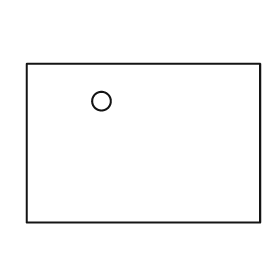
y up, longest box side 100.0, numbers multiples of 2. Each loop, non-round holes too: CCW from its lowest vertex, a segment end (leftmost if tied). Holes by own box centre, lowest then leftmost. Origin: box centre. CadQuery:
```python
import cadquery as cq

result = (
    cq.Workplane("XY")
    .moveTo(-50.0, -34.0)
    .lineTo(50.0, -34.0)
    .lineTo(50.0, 34.0)
    .lineTo(-50.0, 34.0)
    .close()
    .moveTo(-18.0, 18.0)
    .circle(4.0)
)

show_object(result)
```